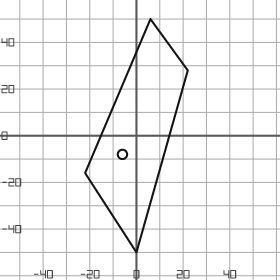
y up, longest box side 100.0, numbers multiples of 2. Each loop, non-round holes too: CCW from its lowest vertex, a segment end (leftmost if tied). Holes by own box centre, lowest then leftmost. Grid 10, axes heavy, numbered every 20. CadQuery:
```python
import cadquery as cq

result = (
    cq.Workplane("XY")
    .moveTo(0.0, -50.0)
    .lineTo(22.0, 28.0)
    .lineTo(6.0, 50.0)
    .lineTo(-22.0, -16.0)
    .close()
    .moveTo(-6.0, -8.0)
    .circle(2.0)
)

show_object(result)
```